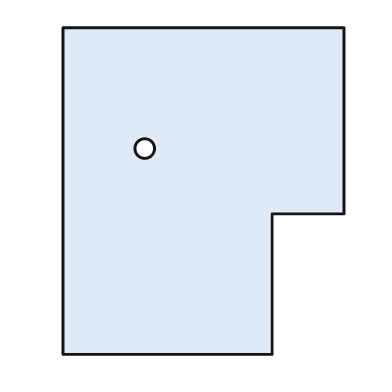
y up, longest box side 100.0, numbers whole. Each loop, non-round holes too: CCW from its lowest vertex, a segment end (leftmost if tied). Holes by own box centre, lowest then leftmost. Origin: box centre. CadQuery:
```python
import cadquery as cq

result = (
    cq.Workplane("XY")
    .moveTo(-43.0, -50.0)
    .lineTo(21.0, -50.0)
    .lineTo(21.0, -7.0)
    .lineTo(43.0, -7.0)
    .lineTo(43.0, 50.0)
    .lineTo(-43.0, 50.0)
    .close()
    .moveTo(-18.0, 13.0)
    .circle(3.0)
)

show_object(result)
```